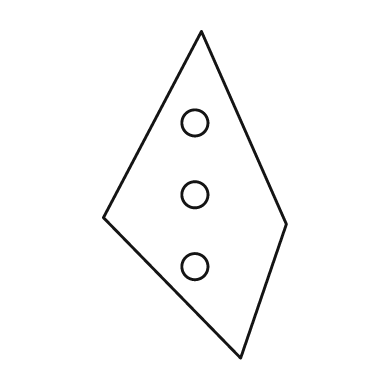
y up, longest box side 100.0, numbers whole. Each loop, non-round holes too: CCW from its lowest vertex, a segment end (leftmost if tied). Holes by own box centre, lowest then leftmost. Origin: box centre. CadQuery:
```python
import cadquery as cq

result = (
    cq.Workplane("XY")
    .moveTo(14.0, -50.0)
    .lineTo(28.0, -9.0)
    .lineTo(2.0, 50.0)
    .lineTo(-28.0, -7.0)
    .close()
    .moveTo(0.0, -22.0)
    .circle(4.0)
    .moveTo(0.0, 0.0)
    .circle(4.0)
    .moveTo(0.0, 22.0)
    .circle(4.0)
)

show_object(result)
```